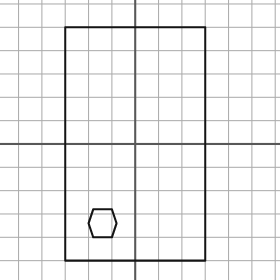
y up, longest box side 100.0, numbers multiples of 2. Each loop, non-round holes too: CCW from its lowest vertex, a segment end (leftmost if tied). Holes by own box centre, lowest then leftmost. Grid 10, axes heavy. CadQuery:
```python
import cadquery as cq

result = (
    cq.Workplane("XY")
    .moveTo(-30.0, -50.0)
    .lineTo(30.0, -50.0)
    .lineTo(30.0, 50.0)
    .lineTo(-30.0, 50.0)
    .close()
    .moveTo(-18.0, -40.0)
    .lineTo(-10.0, -40.0)
    .lineTo(-8.0, -34.0)
    .lineTo(-10.0, -28.0)
    .lineTo(-18.0, -28.0)
    .lineTo(-20.0, -34.0)
    .close()
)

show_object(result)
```